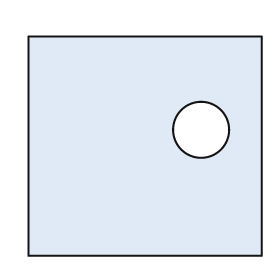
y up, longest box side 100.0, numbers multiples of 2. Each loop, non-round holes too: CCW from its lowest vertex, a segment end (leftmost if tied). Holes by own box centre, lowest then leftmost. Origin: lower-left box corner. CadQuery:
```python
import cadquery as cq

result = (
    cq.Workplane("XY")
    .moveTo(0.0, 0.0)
    .lineTo(100.0, 0.0)
    .lineTo(100.0, 94.0)
    .lineTo(0.0, 94.0)
    .close()
    .moveTo(74.0, 54.0)
    .circle(12.0)
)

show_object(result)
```